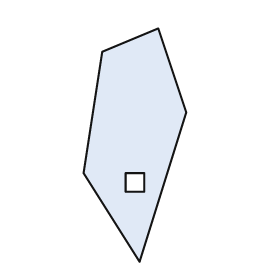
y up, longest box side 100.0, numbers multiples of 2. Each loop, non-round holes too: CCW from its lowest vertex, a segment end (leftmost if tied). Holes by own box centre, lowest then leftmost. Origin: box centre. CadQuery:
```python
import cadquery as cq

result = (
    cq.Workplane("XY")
    .moveTo(2.0, -50.0)
    .lineTo(22.0, 14.0)
    .lineTo(10.0, 50.0)
    .lineTo(-14.0, 40.0)
    .lineTo(-22.0, -12.0)
    .close()
    .moveTo(-4.0, -20.0)
    .lineTo(4.0, -20.0)
    .lineTo(4.0, -12.0)
    .lineTo(-4.0, -12.0)
    .close()
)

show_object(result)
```